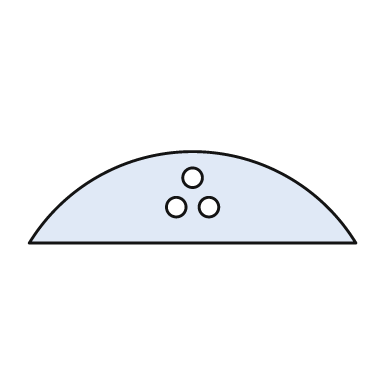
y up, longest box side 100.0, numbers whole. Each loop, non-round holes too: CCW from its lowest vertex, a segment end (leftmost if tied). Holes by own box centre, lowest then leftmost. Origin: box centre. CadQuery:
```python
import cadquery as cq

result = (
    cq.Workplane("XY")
    .moveTo(-50.0, -14.0)
    .lineTo(50.0, -14.0)
    .threePointArc((0.0, 14.0), (-50.0, -14.0))
    .close()
    .moveTo(-5.0, -3.0)
    .circle(3.0)
    .moveTo(5.0, -3.0)
    .circle(3.0)
    .moveTo(0.0, 6.0)
    .circle(3.0)
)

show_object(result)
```